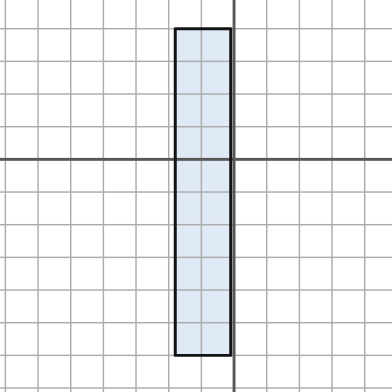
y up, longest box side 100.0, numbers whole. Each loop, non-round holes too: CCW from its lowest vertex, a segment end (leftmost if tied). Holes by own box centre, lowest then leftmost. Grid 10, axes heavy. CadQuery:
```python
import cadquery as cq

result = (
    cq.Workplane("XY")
    .moveTo(-18.0, -60.0)
    .lineTo(-1.0, -60.0)
    .lineTo(-1.0, 40.0)
    .lineTo(-18.0, 40.0)
    .close()
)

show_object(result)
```